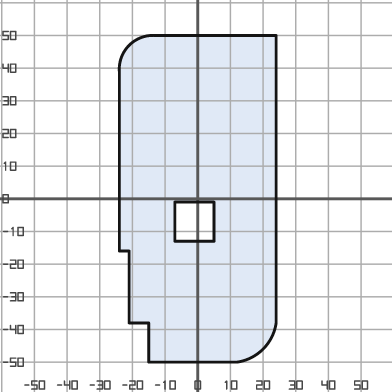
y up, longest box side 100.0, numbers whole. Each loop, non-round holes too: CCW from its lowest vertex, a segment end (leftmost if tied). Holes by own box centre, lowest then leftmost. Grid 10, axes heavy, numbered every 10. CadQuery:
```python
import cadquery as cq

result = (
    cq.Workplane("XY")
    .moveTo(-15.0, -50.0)
    .lineTo(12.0, -50.0)
    .threePointArc((20.0, -46.0), (24.0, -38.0))
    .lineTo(24.0, 50.0)
    .lineTo(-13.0, 50.0)
    .threePointArc((-21.0, 47.0), (-24.0, 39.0))
    .lineTo(-24.0, -16.0)
    .lineTo(-21.0, -16.0)
    .lineTo(-21.0, -38.0)
    .lineTo(-15.0, -38.0)
    .close()
    .moveTo(-7.0, -13.0)
    .lineTo(5.0, -13.0)
    .lineTo(5.0, -1.0)
    .lineTo(-7.0, -1.0)
    .close()
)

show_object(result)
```